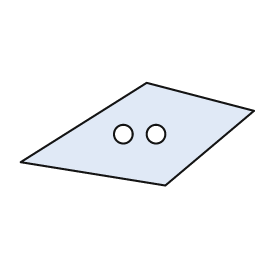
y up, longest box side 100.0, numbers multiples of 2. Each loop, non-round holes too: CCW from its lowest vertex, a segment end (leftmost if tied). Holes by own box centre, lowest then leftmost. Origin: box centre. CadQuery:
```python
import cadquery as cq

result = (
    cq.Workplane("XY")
    .moveTo(12.0, -22.0)
    .lineTo(50.0, 10.0)
    .lineTo(4.0, 22.0)
    .lineTo(-50.0, -12.0)
    .close()
    .moveTo(-6.0, 0.0)
    .circle(4.0)
    .moveTo(8.0, 0.0)
    .circle(4.0)
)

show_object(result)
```